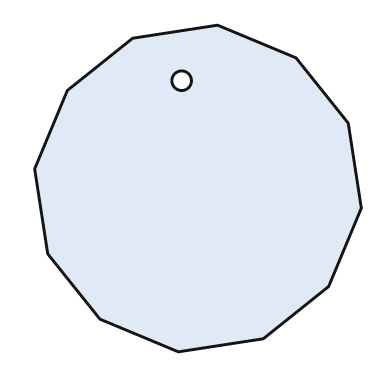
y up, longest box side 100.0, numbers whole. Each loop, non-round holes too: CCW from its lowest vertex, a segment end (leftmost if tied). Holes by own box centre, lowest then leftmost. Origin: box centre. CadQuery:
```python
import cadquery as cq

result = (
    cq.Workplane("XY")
    .moveTo(-6.0, -50.0)
    .lineTo(20.0, -46.0)
    .lineTo(40.0, -30.0)
    .lineTo(50.0, -6.0)
    .lineTo(46.0, 20.0)
    .lineTo(30.0, 40.0)
    .lineTo(6.0, 50.0)
    .lineTo(-20.0, 46.0)
    .lineTo(-40.0, 30.0)
    .lineTo(-50.0, 6.0)
    .lineTo(-46.0, -20.0)
    .lineTo(-30.0, -40.0)
    .close()
    .moveTo(-5.0, 33.0)
    .circle(3.0)
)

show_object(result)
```